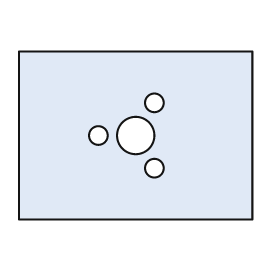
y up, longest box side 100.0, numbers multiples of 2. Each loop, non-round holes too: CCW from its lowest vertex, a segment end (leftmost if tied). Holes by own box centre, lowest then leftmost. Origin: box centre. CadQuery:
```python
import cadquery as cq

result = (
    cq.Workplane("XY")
    .moveTo(-50.0, -36.0)
    .lineTo(50.0, -36.0)
    .lineTo(50.0, 36.0)
    .lineTo(-50.0, 36.0)
    .close()
    .moveTo(8.0, -14.0)
    .circle(4.0)
    .moveTo(-16.0, 0.0)
    .circle(4.0)
    .moveTo(0.0, 0.0)
    .circle(8.0)
    .moveTo(8.0, 14.0)
    .circle(4.0)
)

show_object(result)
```